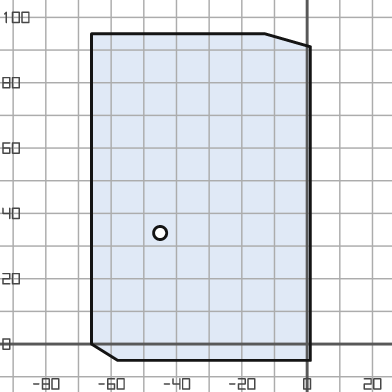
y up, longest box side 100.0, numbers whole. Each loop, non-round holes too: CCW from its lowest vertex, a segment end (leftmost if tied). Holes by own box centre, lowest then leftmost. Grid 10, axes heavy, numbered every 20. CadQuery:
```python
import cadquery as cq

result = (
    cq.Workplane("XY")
    .moveTo(-58.0, -5.0)
    .lineTo(1.0, -5.0)
    .lineTo(1.0, 91.0)
    .lineTo(-13.0, 95.0)
    .lineTo(-66.0, 95.0)
    .lineTo(-66.0, 0.0)
    .close()
    .moveTo(-45.0, 34.0)
    .circle(2.0)
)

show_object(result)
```